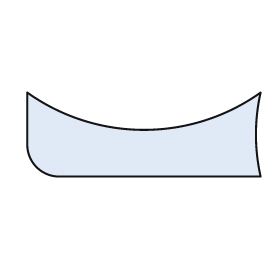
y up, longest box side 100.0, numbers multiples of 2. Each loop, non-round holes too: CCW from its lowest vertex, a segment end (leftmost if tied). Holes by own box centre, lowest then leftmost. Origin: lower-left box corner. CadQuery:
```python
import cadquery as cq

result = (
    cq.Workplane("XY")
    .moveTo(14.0, 0.0)
    .lineTo(100.0, 0.0)
    .threePointArc((98.0, 18.0), (100.0, 36.0))
    .threePointArc((50.0, 20.0), (0.0, 36.0))
    .lineTo(0.0, 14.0)
    .threePointArc((4.0, 4.0), (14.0, 0.0))
    .close()
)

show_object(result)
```